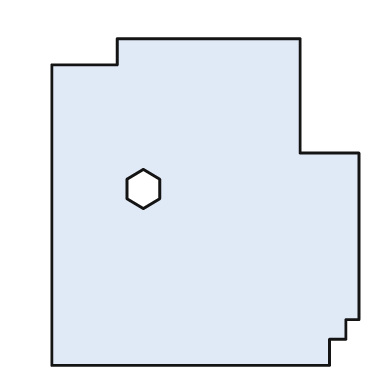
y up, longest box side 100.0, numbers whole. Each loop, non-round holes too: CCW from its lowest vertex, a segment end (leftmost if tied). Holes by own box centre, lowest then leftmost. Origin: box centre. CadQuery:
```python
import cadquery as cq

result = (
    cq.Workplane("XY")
    .moveTo(-47.0, -50.0)
    .lineTo(38.0, -50.0)
    .lineTo(38.0, -42.0)
    .lineTo(43.0, -42.0)
    .lineTo(43.0, -36.0)
    .lineTo(47.0, -36.0)
    .lineTo(47.0, 15.0)
    .lineTo(29.0, 15.0)
    .lineTo(29.0, 50.0)
    .lineTo(-27.0, 50.0)
    .lineTo(-27.0, 42.0)
    .lineTo(-47.0, 42.0)
    .close()
    .moveTo(-19.0, -2.0)
    .lineTo(-14.0, 1.0)
    .lineTo(-14.0, 7.0)
    .lineTo(-19.0, 10.0)
    .lineTo(-24.0, 7.0)
    .lineTo(-24.0, 1.0)
    .close()
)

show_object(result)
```